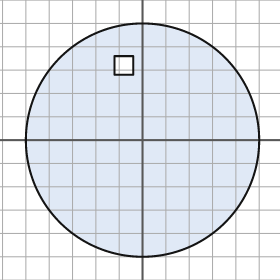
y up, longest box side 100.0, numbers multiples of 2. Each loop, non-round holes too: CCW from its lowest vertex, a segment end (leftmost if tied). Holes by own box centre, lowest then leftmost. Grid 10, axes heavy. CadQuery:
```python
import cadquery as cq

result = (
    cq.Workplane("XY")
    .moveTo(0.0, 0.0)
    .circle(50.0)
    .moveTo(-12.0, 28.0)
    .lineTo(-4.0, 28.0)
    .lineTo(-4.0, 36.0)
    .lineTo(-12.0, 36.0)
    .close()
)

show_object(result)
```